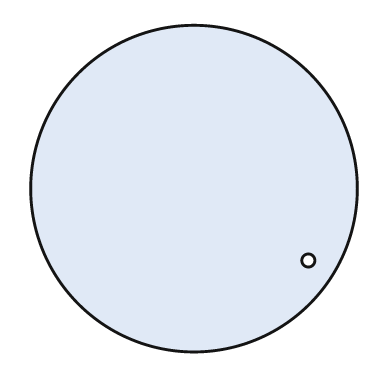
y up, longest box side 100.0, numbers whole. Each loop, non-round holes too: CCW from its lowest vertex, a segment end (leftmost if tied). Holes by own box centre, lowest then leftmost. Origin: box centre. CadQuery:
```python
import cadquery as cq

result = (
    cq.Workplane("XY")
    .moveTo(0.0, 0.0)
    .circle(50.0)
    .moveTo(35.0, -22.0)
    .circle(2.0)
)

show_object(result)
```